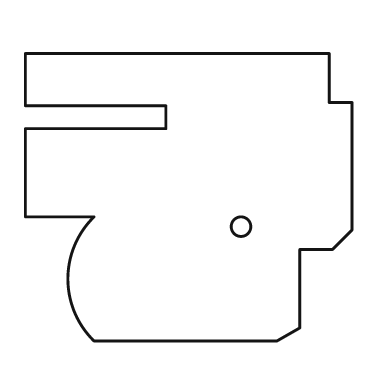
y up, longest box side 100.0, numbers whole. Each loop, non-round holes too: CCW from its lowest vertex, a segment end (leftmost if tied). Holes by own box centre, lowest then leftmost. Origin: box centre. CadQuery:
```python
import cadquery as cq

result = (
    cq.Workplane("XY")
    .moveTo(-29.0, -44.0)
    .lineTo(27.0, -44.0)
    .lineTo(34.0, -40.0)
    .lineTo(34.0, -16.0)
    .lineTo(44.0, -16.0)
    .lineTo(50.0, -10.0)
    .lineTo(50.0, 29.0)
    .lineTo(43.0, 29.0)
    .lineTo(43.0, 44.0)
    .lineTo(-50.0, 44.0)
    .lineTo(-50.0, 28.0)
    .lineTo(-7.0, 28.0)
    .lineTo(-7.0, 21.0)
    .lineTo(-50.0, 21.0)
    .lineTo(-50.0, -6.0)
    .lineTo(-29.0, -6.0)
    .threePointArc((-37.0, -25.0), (-29.0, -44.0))
    .close()
    .moveTo(16.0, -9.0)
    .circle(3.0)
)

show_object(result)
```